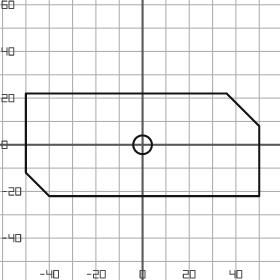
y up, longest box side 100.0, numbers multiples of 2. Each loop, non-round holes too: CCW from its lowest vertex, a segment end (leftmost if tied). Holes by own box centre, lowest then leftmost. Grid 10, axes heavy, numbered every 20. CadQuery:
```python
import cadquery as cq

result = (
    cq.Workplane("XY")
    .moveTo(-40.0, -22.0)
    .lineTo(50.0, -22.0)
    .lineTo(50.0, 8.0)
    .lineTo(36.0, 22.0)
    .lineTo(-50.0, 22.0)
    .lineTo(-50.0, -12.0)
    .close()
    .moveTo(0.0, 0.0)
    .circle(4.0)
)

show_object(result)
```